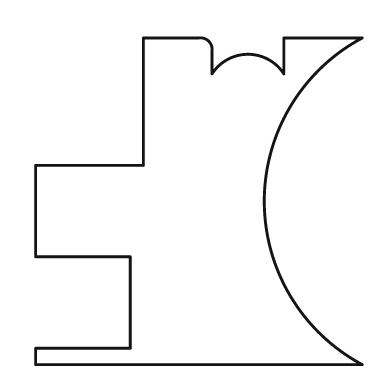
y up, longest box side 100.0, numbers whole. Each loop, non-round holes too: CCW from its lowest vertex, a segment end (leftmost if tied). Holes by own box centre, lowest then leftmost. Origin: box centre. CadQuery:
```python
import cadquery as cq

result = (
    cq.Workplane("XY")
    .moveTo(-50.0, -50.0)
    .lineTo(50.0, -50.0)
    .threePointArc((20.0, 0.0), (50.0, 50.0))
    .lineTo(26.0, 50.0)
    .lineTo(26.0, 39.0)
    .threePointArc((15.0, 45.0), (4.0, 39.0))
    .lineTo(4.0, 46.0)
    .threePointArc((3.0, 49.0), (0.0, 50.0))
    .lineTo(-17.0, 50.0)
    .lineTo(-17.0, 11.0)
    .lineTo(-50.0, 11.0)
    .lineTo(-50.0, -17.0)
    .lineTo(-21.0, -17.0)
    .lineTo(-21.0, -45.0)
    .lineTo(-50.0, -45.0)
    .close()
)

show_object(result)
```